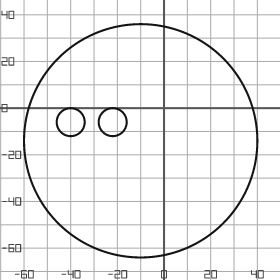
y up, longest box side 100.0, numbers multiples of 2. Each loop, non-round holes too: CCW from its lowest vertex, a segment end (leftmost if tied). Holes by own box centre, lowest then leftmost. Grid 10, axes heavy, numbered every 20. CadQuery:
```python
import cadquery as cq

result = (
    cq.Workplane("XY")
    .moveTo(-10.0, -14.0)
    .circle(50.0)
    .moveTo(-40.0, -6.0)
    .circle(6.0)
    .moveTo(-22.0, -6.0)
    .circle(6.0)
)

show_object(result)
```